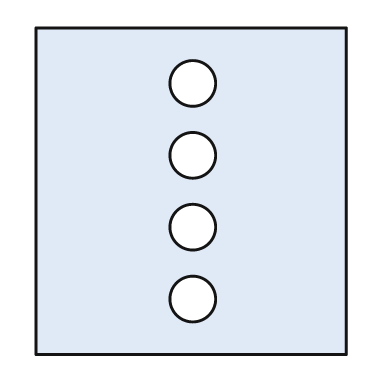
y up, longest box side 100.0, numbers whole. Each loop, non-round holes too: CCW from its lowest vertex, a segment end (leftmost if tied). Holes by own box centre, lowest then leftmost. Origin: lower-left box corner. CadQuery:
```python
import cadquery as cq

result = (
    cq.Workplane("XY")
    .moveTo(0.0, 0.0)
    .lineTo(95.0, 0.0)
    .lineTo(95.0, 100.0)
    .lineTo(0.0, 100.0)
    .close()
    .moveTo(48.0, 17.0)
    .circle(7.0)
    .moveTo(48.0, 39.0)
    .circle(7.0)
    .moveTo(48.0, 61.0)
    .circle(7.0)
    .moveTo(48.0, 83.0)
    .circle(7.0)
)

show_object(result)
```